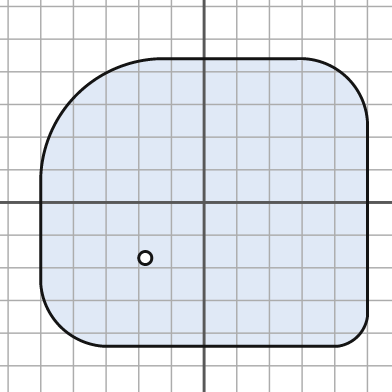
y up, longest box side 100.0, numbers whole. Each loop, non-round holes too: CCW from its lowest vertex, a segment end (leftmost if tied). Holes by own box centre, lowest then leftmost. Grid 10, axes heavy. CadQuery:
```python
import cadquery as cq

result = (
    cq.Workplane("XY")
    .moveTo(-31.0, -44.0)
    .lineTo(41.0, -44.0)
    .threePointArc((47.0, -41.0), (50.0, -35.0))
    .lineTo(50.0, 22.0)
    .threePointArc((44.0, 38.0), (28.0, 44.0))
    .lineTo(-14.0, 44.0)
    .threePointArc((-39.0, 33.0), (-50.0, 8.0))
    .lineTo(-50.0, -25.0)
    .threePointArc((-44.0, -38.0), (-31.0, -44.0))
    .close()
    .moveTo(-18.0, -17.0)
    .circle(2.0)
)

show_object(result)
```